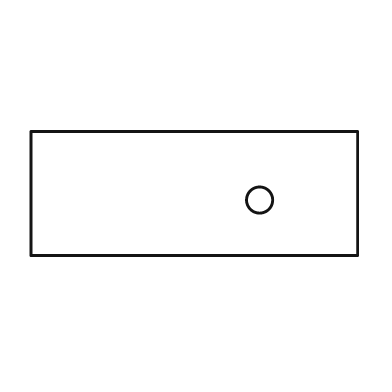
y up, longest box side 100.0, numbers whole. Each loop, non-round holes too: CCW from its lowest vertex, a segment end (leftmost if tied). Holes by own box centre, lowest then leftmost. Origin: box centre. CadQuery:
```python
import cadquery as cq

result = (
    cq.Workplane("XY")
    .moveTo(-50.0, -19.0)
    .lineTo(50.0, -19.0)
    .lineTo(50.0, 19.0)
    .lineTo(-50.0, 19.0)
    .close()
    .moveTo(20.0, -2.0)
    .circle(4.0)
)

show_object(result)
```